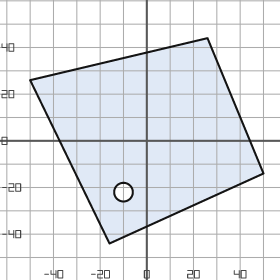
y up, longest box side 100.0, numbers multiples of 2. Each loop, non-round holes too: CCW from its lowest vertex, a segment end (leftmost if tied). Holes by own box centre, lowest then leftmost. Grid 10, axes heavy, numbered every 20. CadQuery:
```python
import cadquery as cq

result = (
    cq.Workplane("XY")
    .moveTo(-16.0, -44.0)
    .lineTo(50.0, -14.0)
    .lineTo(26.0, 44.0)
    .lineTo(-50.0, 26.0)
    .close()
    .moveTo(-10.0, -22.0)
    .circle(4.0)
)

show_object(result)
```